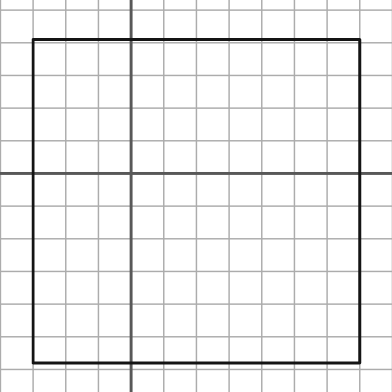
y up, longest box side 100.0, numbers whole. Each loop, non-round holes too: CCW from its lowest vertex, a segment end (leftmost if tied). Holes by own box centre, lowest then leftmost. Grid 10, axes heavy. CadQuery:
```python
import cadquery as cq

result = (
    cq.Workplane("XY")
    .moveTo(-30.0, -58.0)
    .lineTo(70.0, -58.0)
    .lineTo(70.0, 41.0)
    .lineTo(-30.0, 41.0)
    .close()
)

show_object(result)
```